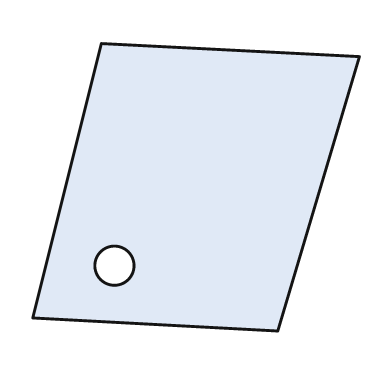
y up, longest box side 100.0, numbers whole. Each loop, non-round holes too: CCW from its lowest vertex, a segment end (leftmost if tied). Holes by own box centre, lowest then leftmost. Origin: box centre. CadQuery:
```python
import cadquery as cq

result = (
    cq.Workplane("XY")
    .moveTo(25.0, -44.0)
    .lineTo(50.0, 40.0)
    .lineTo(-29.0, 44.0)
    .lineTo(-50.0, -40.0)
    .close()
    .moveTo(-25.0, -24.0)
    .circle(6.0)
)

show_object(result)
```